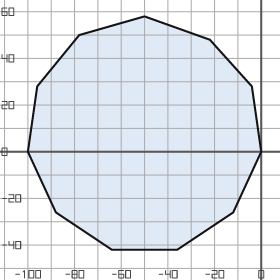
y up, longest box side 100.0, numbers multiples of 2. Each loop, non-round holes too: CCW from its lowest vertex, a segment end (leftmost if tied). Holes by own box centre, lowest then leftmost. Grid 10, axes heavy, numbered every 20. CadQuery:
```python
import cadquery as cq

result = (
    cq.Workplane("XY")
    .moveTo(-64.0, -42.0)
    .lineTo(-36.0, -42.0)
    .lineTo(-12.0, -26.0)
    .lineTo(0.0, 0.0)
    .lineTo(-4.0, 28.0)
    .lineTo(-22.0, 48.0)
    .lineTo(-50.0, 58.0)
    .lineTo(-78.0, 50.0)
    .lineTo(-96.0, 28.0)
    .lineTo(-100.0, 0.0)
    .lineTo(-88.0, -26.0)
    .close()
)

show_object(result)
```